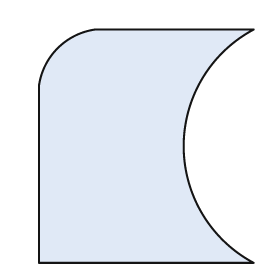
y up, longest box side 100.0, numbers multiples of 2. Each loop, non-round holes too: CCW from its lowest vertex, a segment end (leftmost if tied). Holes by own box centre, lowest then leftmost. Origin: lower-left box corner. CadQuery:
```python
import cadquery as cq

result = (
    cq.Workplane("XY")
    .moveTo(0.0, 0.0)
    .lineTo(92.0, 0.0)
    .threePointArc((62.0, 50.0), (92.0, 100.0))
    .lineTo(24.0, 100.0)
    .threePointArc((8.0, 92.0), (0.0, 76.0))
    .close()
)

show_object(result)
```